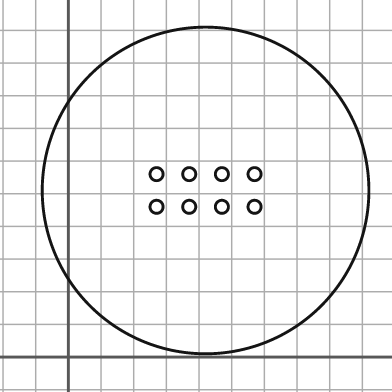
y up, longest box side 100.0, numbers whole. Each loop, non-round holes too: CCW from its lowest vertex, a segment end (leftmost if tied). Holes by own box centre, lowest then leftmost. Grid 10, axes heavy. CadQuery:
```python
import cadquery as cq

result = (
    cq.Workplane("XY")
    .moveTo(42.0, 51.0)
    .circle(50.0)
    .moveTo(27.0, 46.0)
    .circle(2.0)
    .moveTo(37.0, 46.0)
    .circle(2.0)
    .moveTo(47.0, 46.0)
    .circle(2.0)
    .moveTo(57.0, 46.0)
    .circle(2.0)
    .moveTo(27.0, 56.0)
    .circle(2.0)
    .moveTo(37.0, 56.0)
    .circle(2.0)
    .moveTo(47.0, 56.0)
    .circle(2.0)
    .moveTo(57.0, 56.0)
    .circle(2.0)
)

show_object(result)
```